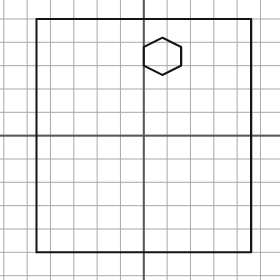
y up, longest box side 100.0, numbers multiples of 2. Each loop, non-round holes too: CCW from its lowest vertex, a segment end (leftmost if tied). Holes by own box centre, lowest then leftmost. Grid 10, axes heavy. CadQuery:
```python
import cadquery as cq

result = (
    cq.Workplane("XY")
    .moveTo(-46.0, -50.0)
    .lineTo(46.0, -50.0)
    .lineTo(46.0, 50.0)
    .lineTo(-46.0, 50.0)
    .close()
    .moveTo(8.0, 26.0)
    .lineTo(16.0, 30.0)
    .lineTo(16.0, 38.0)
    .lineTo(8.0, 42.0)
    .lineTo(0.0, 38.0)
    .lineTo(0.0, 30.0)
    .close()
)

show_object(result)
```